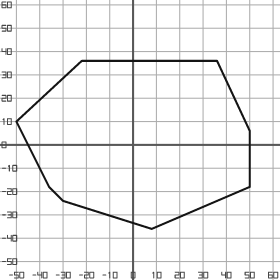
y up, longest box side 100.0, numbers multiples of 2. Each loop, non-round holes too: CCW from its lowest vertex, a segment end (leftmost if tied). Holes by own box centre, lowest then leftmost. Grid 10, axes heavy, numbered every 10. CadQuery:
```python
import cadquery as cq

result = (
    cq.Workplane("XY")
    .moveTo(8.0, -36.0)
    .lineTo(50.0, -18.0)
    .lineTo(50.0, 6.0)
    .lineTo(36.0, 36.0)
    .lineTo(-22.0, 36.0)
    .lineTo(-50.0, 10.0)
    .lineTo(-36.0, -18.0)
    .lineTo(-30.0, -24.0)
    .close()
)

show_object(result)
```